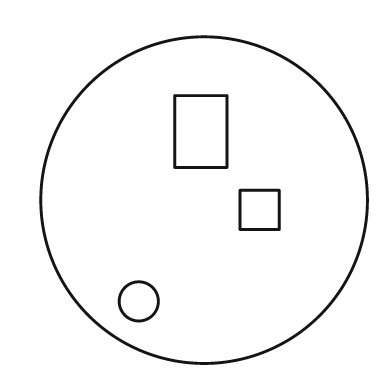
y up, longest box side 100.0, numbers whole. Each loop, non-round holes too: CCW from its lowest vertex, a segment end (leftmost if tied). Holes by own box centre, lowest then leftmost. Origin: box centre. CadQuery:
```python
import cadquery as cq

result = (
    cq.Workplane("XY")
    .moveTo(0.0, 0.0)
    .circle(50.0)
    .moveTo(-20.0, -31.0)
    .circle(6.0)
    .moveTo(11.0, -9.0)
    .lineTo(23.0, -9.0)
    .lineTo(23.0, 3.0)
    .lineTo(11.0, 3.0)
    .close()
    .moveTo(-9.0, 10.0)
    .lineTo(7.0, 10.0)
    .lineTo(7.0, 32.0)
    .lineTo(-9.0, 32.0)
    .close()
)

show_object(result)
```